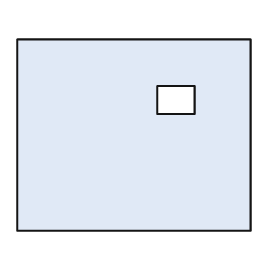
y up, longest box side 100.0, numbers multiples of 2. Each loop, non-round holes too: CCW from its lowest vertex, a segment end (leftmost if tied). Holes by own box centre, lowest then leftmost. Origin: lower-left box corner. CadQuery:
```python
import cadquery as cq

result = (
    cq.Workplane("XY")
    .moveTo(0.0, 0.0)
    .lineTo(100.0, 0.0)
    .lineTo(100.0, 82.0)
    .lineTo(0.0, 82.0)
    .close()
    .moveTo(60.0, 50.0)
    .lineTo(76.0, 50.0)
    .lineTo(76.0, 62.0)
    .lineTo(60.0, 62.0)
    .close()
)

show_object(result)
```